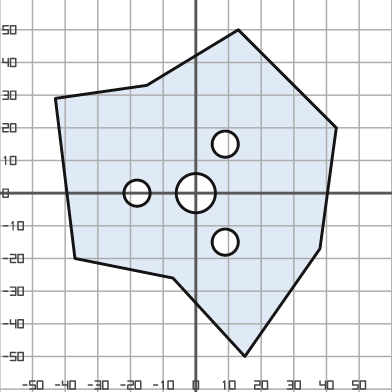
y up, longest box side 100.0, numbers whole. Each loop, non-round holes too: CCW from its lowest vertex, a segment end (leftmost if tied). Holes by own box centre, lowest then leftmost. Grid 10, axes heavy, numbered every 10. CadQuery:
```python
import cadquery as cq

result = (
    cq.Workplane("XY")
    .moveTo(15.0, -50.0)
    .lineTo(38.0, -17.0)
    .lineTo(43.0, 20.0)
    .lineTo(13.0, 50.0)
    .lineTo(-15.0, 33.0)
    .lineTo(-43.0, 29.0)
    .lineTo(-37.0, -20.0)
    .lineTo(-7.0, -26.0)
    .close()
    .moveTo(9.0, -15.0)
    .circle(4.0)
    .moveTo(-18.0, 0.0)
    .circle(4.0)
    .moveTo(0.0, 0.0)
    .circle(6.0)
    .moveTo(9.0, 15.0)
    .circle(4.0)
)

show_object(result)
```